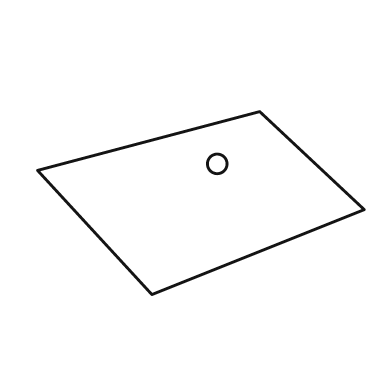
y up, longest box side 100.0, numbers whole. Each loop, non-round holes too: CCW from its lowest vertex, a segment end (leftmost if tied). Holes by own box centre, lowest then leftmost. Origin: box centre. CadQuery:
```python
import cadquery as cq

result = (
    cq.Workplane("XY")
    .moveTo(-15.0, -28.0)
    .lineTo(50.0, -2.0)
    .lineTo(18.0, 28.0)
    .lineTo(-50.0, 10.0)
    .close()
    .moveTo(5.0, 12.0)
    .circle(3.0)
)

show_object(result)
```